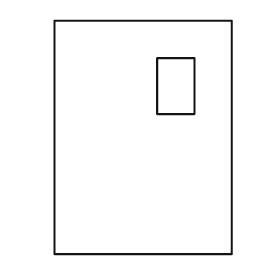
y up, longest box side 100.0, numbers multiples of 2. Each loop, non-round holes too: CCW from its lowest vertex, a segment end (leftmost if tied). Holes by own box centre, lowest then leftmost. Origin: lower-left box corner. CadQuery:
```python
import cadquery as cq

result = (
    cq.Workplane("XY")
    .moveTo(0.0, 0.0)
    .lineTo(76.0, 0.0)
    .lineTo(76.0, 100.0)
    .lineTo(0.0, 100.0)
    .close()
    .moveTo(44.0, 60.0)
    .lineTo(60.0, 60.0)
    .lineTo(60.0, 84.0)
    .lineTo(44.0, 84.0)
    .close()
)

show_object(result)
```